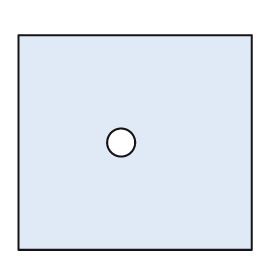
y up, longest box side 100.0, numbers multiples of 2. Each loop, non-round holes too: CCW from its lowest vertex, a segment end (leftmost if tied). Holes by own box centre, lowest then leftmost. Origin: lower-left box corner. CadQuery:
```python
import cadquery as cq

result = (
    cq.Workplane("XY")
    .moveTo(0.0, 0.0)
    .lineTo(100.0, 0.0)
    .lineTo(100.0, 92.0)
    .lineTo(0.0, 92.0)
    .close()
    .moveTo(44.0, 46.0)
    .circle(6.0)
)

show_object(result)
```